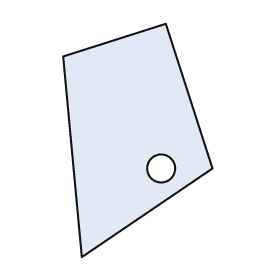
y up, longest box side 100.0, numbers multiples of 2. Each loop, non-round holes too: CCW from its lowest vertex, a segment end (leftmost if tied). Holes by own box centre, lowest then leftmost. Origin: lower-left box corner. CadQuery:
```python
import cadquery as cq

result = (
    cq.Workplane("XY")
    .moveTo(8.0, 0.0)
    .lineTo(64.0, 38.0)
    .lineTo(44.0, 100.0)
    .lineTo(0.0, 86.0)
    .close()
    .moveTo(42.0, 38.0)
    .circle(6.0)
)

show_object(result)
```